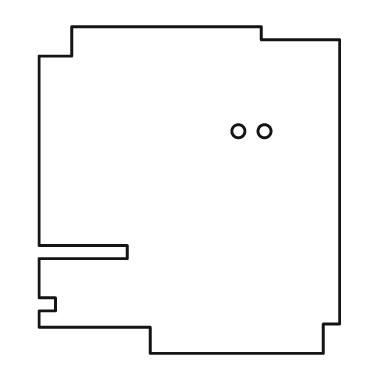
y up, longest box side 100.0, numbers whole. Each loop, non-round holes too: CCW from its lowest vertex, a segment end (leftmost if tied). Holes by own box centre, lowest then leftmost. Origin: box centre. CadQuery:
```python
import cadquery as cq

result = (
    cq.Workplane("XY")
    .moveTo(-12.0, -50.0)
    .lineTo(41.0, -50.0)
    .lineTo(41.0, -41.0)
    .lineTo(46.0, -41.0)
    .lineTo(46.0, 46.0)
    .lineTo(22.0, 46.0)
    .lineTo(22.0, 50.0)
    .lineTo(-36.0, 50.0)
    .lineTo(-36.0, 41.0)
    .lineTo(-46.0, 41.0)
    .lineTo(-46.0, -17.0)
    .lineTo(-19.0, -17.0)
    .lineTo(-19.0, -21.0)
    .lineTo(-46.0, -21.0)
    .lineTo(-46.0, -33.0)
    .lineTo(-41.0, -33.0)
    .lineTo(-41.0, -37.0)
    .lineTo(-46.0, -37.0)
    .lineTo(-46.0, -42.0)
    .lineTo(-12.0, -42.0)
    .close()
    .moveTo(15.0, 18.0)
    .circle(2.0)
    .moveTo(23.0, 18.0)
    .circle(2.0)
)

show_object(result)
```